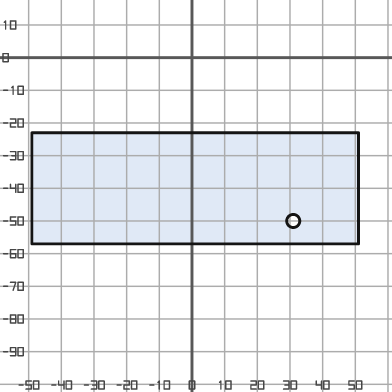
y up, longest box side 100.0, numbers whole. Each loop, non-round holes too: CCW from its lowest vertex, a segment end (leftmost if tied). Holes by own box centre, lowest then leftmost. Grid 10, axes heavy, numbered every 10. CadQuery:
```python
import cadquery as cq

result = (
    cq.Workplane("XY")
    .moveTo(-49.0, -57.0)
    .lineTo(51.0, -57.0)
    .lineTo(51.0, -23.0)
    .lineTo(-49.0, -23.0)
    .close()
    .moveTo(31.0, -50.0)
    .circle(2.0)
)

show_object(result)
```